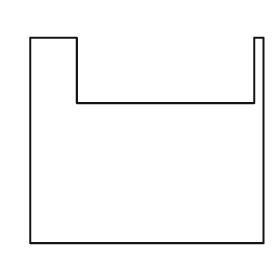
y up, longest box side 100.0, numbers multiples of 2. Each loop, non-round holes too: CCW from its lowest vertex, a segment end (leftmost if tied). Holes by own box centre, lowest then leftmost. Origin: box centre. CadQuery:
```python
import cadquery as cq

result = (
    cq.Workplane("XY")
    .moveTo(-50.0, -44.0)
    .lineTo(50.0, -44.0)
    .lineTo(50.0, 44.0)
    .lineTo(46.0, 44.0)
    .lineTo(46.0, 16.0)
    .lineTo(-30.0, 16.0)
    .lineTo(-30.0, 44.0)
    .lineTo(-50.0, 44.0)
    .close()
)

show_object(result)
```